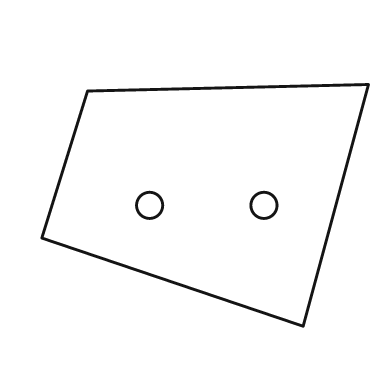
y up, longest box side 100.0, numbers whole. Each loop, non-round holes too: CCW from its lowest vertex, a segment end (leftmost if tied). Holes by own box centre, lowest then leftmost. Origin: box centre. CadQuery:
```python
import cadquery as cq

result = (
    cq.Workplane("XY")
    .moveTo(30.0, -37.0)
    .lineTo(50.0, 37.0)
    .lineTo(-36.0, 35.0)
    .lineTo(-50.0, -10.0)
    .close()
    .moveTo(-17.0, 0.0)
    .circle(4.0)
    .moveTo(18.0, 0.0)
    .circle(4.0)
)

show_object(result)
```